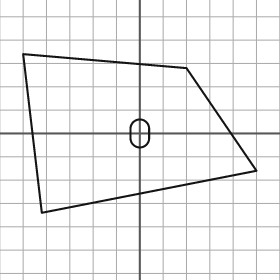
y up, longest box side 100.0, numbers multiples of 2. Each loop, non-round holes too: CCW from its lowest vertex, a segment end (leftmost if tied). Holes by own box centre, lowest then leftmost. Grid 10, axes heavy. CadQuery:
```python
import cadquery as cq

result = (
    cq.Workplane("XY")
    .moveTo(-42.0, -34.0)
    .lineTo(50.0, -16.0)
    .lineTo(20.0, 28.0)
    .lineTo(-50.0, 34.0)
    .close()
    .moveTo(-4.0, -2.0)
    .threePointArc((0.0, -6.0), (4.0, -2.0))
    .lineTo(4.0, 2.0)
    .threePointArc((0.0, 6.0), (-4.0, 2.0))
    .close()
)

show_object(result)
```